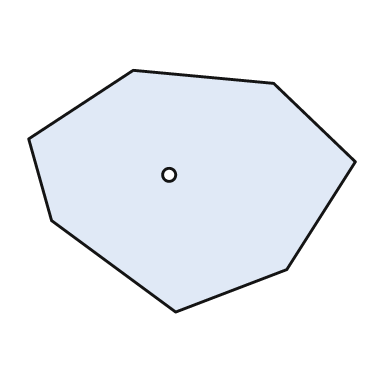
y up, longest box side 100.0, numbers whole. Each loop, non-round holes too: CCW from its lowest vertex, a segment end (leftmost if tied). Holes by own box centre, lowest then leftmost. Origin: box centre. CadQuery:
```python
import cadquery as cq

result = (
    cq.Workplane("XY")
    .moveTo(-5.0, -37.0)
    .lineTo(29.0, -24.0)
    .lineTo(50.0, 9.0)
    .lineTo(25.0, 33.0)
    .lineTo(-18.0, 37.0)
    .lineTo(-50.0, 16.0)
    .lineTo(-43.0, -9.0)
    .close()
    .moveTo(-7.0, 5.0)
    .circle(2.0)
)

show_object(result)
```